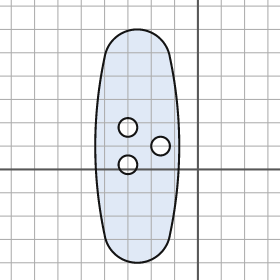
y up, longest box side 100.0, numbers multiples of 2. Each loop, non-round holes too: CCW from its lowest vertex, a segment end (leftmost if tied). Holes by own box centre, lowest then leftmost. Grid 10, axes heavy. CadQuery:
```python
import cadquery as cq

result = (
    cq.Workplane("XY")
    .moveTo(-40.0, -28.0)
    .threePointArc((-26.0, -40.0), (-12.0, -28.0))
    .threePointArc((-8.0, 10.0), (-12.0, 48.0))
    .threePointArc((-26.0, 60.0), (-40.0, 48.0))
    .threePointArc((-44.0, 10.0), (-40.0, -28.0))
    .close()
    .moveTo(-30.0, 2.0)
    .circle(4.0)
    .moveTo(-16.0, 10.0)
    .circle(4.0)
    .moveTo(-30.0, 18.0)
    .circle(4.0)
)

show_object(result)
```